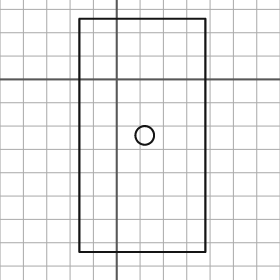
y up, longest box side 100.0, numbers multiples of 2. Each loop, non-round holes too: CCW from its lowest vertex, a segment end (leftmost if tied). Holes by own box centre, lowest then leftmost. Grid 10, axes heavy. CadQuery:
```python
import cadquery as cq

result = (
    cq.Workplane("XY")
    .moveTo(-16.0, -74.0)
    .lineTo(38.0, -74.0)
    .lineTo(38.0, 26.0)
    .lineTo(-16.0, 26.0)
    .close()
    .moveTo(12.0, -24.0)
    .circle(4.0)
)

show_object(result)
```